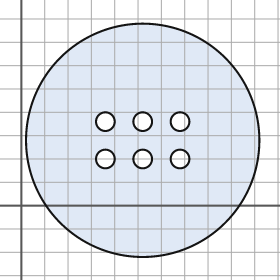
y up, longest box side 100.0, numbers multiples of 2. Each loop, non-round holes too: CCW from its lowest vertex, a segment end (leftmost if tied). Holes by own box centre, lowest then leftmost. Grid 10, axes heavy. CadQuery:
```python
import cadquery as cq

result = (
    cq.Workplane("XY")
    .moveTo(52.0, 28.0)
    .circle(50.0)
    .moveTo(36.0, 20.0)
    .circle(4.0)
    .moveTo(52.0, 20.0)
    .circle(4.0)
    .moveTo(68.0, 20.0)
    .circle(4.0)
    .moveTo(36.0, 36.0)
    .circle(4.0)
    .moveTo(52.0, 36.0)
    .circle(4.0)
    .moveTo(68.0, 36.0)
    .circle(4.0)
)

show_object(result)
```